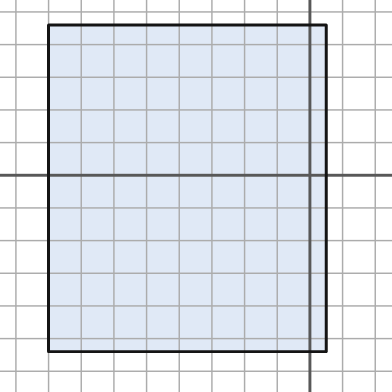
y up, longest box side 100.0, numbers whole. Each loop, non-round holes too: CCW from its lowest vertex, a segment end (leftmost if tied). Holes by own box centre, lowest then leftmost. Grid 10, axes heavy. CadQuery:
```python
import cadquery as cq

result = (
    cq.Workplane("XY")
    .moveTo(-80.0, -54.0)
    .lineTo(5.0, -54.0)
    .lineTo(5.0, 46.0)
    .lineTo(-80.0, 46.0)
    .close()
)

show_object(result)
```